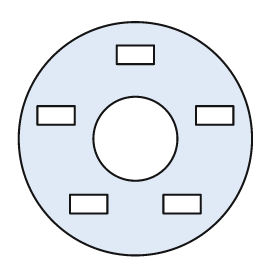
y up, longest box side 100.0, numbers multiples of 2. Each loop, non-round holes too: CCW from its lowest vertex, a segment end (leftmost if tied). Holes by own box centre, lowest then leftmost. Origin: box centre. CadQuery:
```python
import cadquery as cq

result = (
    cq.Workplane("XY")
    .moveTo(0.0, 0.0)
    .circle(50.0)
    .moveTo(-28.0, -32.0)
    .lineTo(-12.0, -32.0)
    .lineTo(-12.0, -24.0)
    .lineTo(-28.0, -24.0)
    .close()
    .moveTo(12.0, -32.0)
    .lineTo(28.0, -32.0)
    .lineTo(28.0, -24.0)
    .lineTo(12.0, -24.0)
    .close()
    .moveTo(0.0, 0.0)
    .circle(18.0)
    .moveTo(-42.0, 6.0)
    .lineTo(-26.0, 6.0)
    .lineTo(-26.0, 14.0)
    .lineTo(-42.0, 14.0)
    .close()
    .moveTo(26.0, 6.0)
    .lineTo(42.0, 6.0)
    .lineTo(42.0, 14.0)
    .lineTo(26.0, 14.0)
    .close()
    .moveTo(-8.0, 32.0)
    .lineTo(8.0, 32.0)
    .lineTo(8.0, 40.0)
    .lineTo(-8.0, 40.0)
    .close()
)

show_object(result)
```